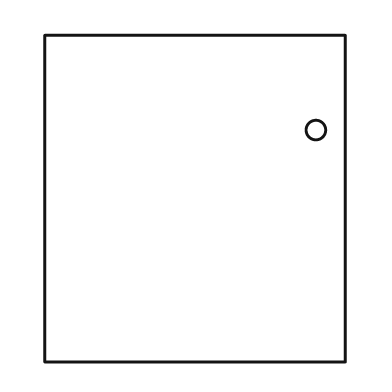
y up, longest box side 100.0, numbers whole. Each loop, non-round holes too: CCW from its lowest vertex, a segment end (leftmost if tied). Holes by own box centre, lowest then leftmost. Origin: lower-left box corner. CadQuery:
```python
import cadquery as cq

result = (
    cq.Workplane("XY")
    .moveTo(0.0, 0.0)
    .lineTo(92.0, 0.0)
    .lineTo(92.0, 100.0)
    .lineTo(0.0, 100.0)
    .close()
    .moveTo(83.0, 71.0)
    .circle(3.0)
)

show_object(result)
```